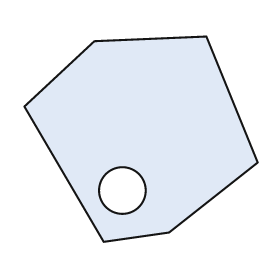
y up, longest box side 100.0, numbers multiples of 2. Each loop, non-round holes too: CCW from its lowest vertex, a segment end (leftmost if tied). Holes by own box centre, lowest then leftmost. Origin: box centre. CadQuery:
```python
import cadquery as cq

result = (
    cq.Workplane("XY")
    .moveTo(-16.0, -44.0)
    .lineTo(12.0, -40.0)
    .lineTo(50.0, -10.0)
    .lineTo(28.0, 44.0)
    .lineTo(-20.0, 42.0)
    .lineTo(-50.0, 14.0)
    .close()
    .moveTo(-8.0, -22.0)
    .circle(10.0)
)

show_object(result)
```